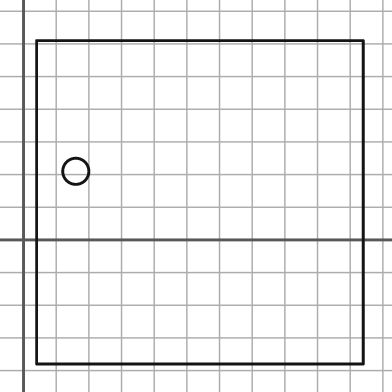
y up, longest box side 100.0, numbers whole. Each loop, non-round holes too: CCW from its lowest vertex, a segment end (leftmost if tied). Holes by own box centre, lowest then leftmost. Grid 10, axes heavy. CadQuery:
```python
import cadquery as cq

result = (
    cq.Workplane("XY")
    .moveTo(4.0, -38.0)
    .lineTo(104.0, -38.0)
    .lineTo(104.0, 61.0)
    .lineTo(4.0, 61.0)
    .close()
    .moveTo(16.0, 21.0)
    .circle(4.0)
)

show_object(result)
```